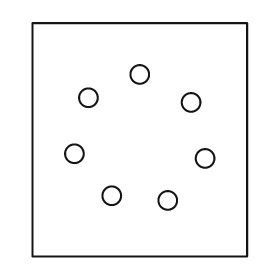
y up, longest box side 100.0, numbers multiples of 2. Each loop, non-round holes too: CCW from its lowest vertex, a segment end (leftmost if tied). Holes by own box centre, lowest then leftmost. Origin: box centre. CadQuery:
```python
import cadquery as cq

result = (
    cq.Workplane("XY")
    .moveTo(-46.0, -50.0)
    .lineTo(46.0, -50.0)
    .lineTo(46.0, 50.0)
    .lineTo(-46.0, 50.0)
    .close()
    .moveTo(12.0, -26.0)
    .circle(4.0)
    .moveTo(-12.0, -24.0)
    .circle(4.0)
    .moveTo(28.0, -8.0)
    .circle(4.0)
    .moveTo(-28.0, -6.0)
    .circle(4.0)
    .moveTo(22.0, 16.0)
    .circle(4.0)
    .moveTo(-22.0, 18.0)
    .circle(4.0)
    .moveTo(0.0, 28.0)
    .circle(4.0)
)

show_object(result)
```